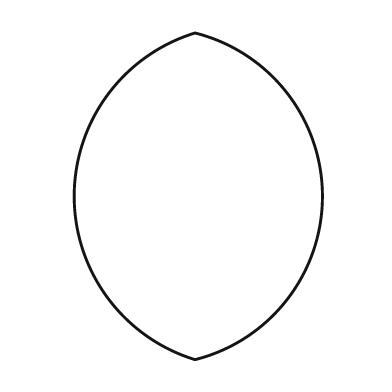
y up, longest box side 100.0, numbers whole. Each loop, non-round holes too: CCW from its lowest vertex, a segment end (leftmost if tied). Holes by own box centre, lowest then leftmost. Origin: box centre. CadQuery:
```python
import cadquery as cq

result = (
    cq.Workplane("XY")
    .moveTo(-1.0, -50.0)
    .threePointArc((38.0, 0.0), (-1.0, 50.0))
    .threePointArc((-38.0, 0.0), (-1.0, -50.0))
    .close()
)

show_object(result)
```